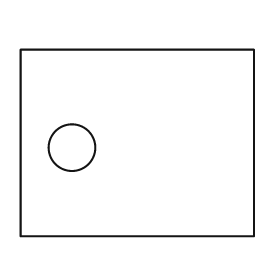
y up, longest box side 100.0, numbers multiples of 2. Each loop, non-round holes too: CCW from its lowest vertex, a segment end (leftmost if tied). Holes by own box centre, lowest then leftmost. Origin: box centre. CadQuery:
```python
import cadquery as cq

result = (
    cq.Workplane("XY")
    .moveTo(-50.0, -40.0)
    .lineTo(50.0, -40.0)
    .lineTo(50.0, 40.0)
    .lineTo(-50.0, 40.0)
    .close()
    .moveTo(-28.0, -2.0)
    .circle(10.0)
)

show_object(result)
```